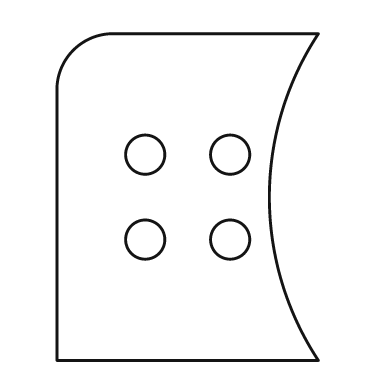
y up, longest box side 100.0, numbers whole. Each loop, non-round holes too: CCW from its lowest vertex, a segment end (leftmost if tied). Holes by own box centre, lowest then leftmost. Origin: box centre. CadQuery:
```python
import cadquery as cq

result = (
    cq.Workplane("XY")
    .moveTo(-40.0, -50.0)
    .lineTo(40.0, -50.0)
    .threePointArc((25.0, 0.0), (40.0, 50.0))
    .lineTo(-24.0, 50.0)
    .threePointArc((-35.0, 45.0), (-40.0, 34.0))
    .close()
    .moveTo(-13.0, -13.0)
    .circle(6.0)
    .moveTo(13.0, -13.0)
    .circle(6.0)
    .moveTo(-13.0, 13.0)
    .circle(6.0)
    .moveTo(13.0, 13.0)
    .circle(6.0)
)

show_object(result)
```